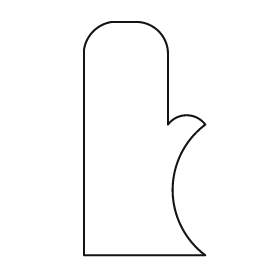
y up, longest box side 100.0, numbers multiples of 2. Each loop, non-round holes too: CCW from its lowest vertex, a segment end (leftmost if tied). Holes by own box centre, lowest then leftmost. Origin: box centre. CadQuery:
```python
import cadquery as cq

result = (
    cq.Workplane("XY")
    .moveTo(-26.0, -50.0)
    .lineTo(26.0, -50.0)
    .threePointArc((12.0, -22.0), (26.0, 6.0))
    .threePointArc((18.0, 10.0), (10.0, 6.0))
    .lineTo(10.0, 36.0)
    .threePointArc((6.0, 46.0), (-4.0, 50.0))
    .lineTo(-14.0, 50.0)
    .threePointArc((-22.0, 46.0), (-26.0, 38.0))
    .close()
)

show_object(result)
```